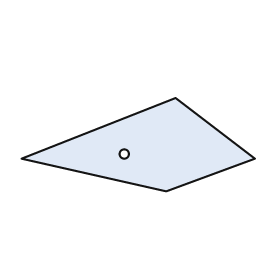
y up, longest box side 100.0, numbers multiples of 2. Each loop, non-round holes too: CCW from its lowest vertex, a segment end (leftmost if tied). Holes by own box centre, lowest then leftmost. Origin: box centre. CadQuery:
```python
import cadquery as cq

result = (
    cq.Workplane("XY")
    .moveTo(12.0, -20.0)
    .lineTo(50.0, -6.0)
    .lineTo(16.0, 20.0)
    .lineTo(-50.0, -6.0)
    .close()
    .moveTo(-6.0, -4.0)
    .circle(2.0)
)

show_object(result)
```